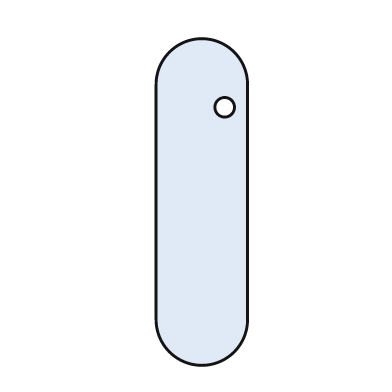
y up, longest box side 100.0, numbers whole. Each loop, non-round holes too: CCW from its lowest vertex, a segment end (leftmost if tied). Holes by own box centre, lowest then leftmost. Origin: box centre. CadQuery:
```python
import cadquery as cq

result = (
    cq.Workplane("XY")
    .moveTo(-14.0, -36.0)
    .threePointArc((0.0, -50.0), (14.0, -36.0))
    .lineTo(14.0, 36.0)
    .threePointArc((0.0, 50.0), (-14.0, 36.0))
    .close()
    .moveTo(7.0, 29.0)
    .circle(3.0)
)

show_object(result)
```